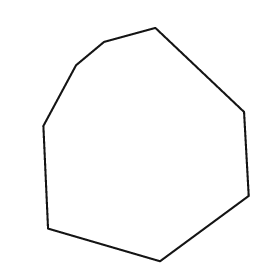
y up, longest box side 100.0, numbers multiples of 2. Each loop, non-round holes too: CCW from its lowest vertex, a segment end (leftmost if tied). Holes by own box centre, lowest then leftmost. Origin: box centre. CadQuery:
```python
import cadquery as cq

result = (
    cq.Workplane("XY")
    .moveTo(6.0, -50.0)
    .lineTo(44.0, -22.0)
    .lineTo(42.0, 14.0)
    .lineTo(4.0, 50.0)
    .lineTo(-18.0, 44.0)
    .lineTo(-30.0, 34.0)
    .lineTo(-44.0, 8.0)
    .lineTo(-42.0, -36.0)
    .close()
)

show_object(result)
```